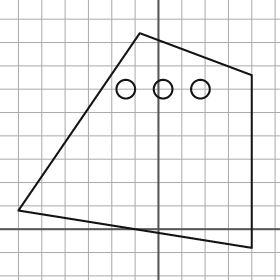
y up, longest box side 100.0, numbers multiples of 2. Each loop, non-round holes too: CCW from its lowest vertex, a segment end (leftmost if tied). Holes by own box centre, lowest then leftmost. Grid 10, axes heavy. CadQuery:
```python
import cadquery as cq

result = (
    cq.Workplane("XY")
    .moveTo(40.0, -8.0)
    .lineTo(40.0, 66.0)
    .lineTo(-8.0, 84.0)
    .lineTo(-60.0, 8.0)
    .close()
    .moveTo(-14.0, 60.0)
    .circle(4.0)
    .moveTo(2.0, 60.0)
    .circle(4.0)
    .moveTo(18.0, 60.0)
    .circle(4.0)
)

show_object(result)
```